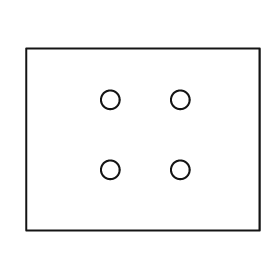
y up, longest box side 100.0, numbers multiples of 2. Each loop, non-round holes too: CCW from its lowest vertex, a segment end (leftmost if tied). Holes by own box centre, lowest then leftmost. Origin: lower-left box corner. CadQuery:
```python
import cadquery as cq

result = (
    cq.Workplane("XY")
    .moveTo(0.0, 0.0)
    .lineTo(100.0, 0.0)
    .lineTo(100.0, 78.0)
    .lineTo(0.0, 78.0)
    .close()
    .moveTo(36.0, 26.0)
    .circle(4.0)
    .moveTo(66.0, 26.0)
    .circle(4.0)
    .moveTo(36.0, 56.0)
    .circle(4.0)
    .moveTo(66.0, 56.0)
    .circle(4.0)
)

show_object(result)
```